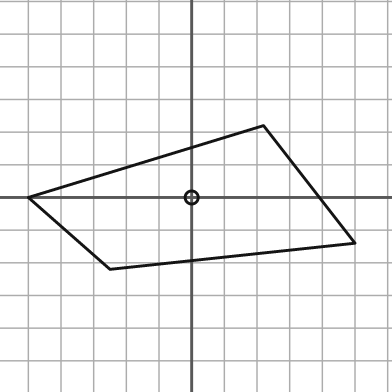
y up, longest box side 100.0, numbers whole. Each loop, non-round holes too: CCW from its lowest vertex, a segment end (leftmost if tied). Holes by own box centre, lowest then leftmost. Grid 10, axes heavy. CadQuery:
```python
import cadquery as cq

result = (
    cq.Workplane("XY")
    .moveTo(-25.0, -22.0)
    .lineTo(50.0, -14.0)
    .lineTo(22.0, 22.0)
    .lineTo(-50.0, 0.0)
    .close()
    .moveTo(0.0, 0.0)
    .circle(2.0)
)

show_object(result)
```